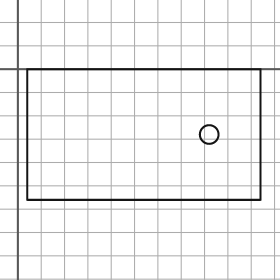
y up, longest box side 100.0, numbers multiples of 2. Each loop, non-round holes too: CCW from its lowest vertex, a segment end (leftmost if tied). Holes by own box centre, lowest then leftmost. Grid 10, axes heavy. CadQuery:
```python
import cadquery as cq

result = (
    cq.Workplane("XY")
    .moveTo(4.0, -56.0)
    .lineTo(104.0, -56.0)
    .lineTo(104.0, 0.0)
    .lineTo(4.0, 0.0)
    .close()
    .moveTo(82.0, -28.0)
    .circle(4.0)
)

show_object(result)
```